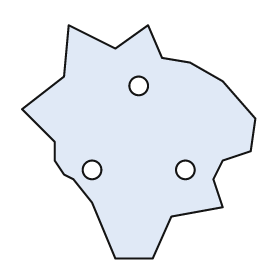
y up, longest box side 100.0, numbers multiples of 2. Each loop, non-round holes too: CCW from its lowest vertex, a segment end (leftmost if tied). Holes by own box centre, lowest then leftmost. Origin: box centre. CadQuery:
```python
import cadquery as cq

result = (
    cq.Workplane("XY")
    .moveTo(-10.0, -50.0)
    .lineTo(6.0, -50.0)
    .lineTo(14.0, -32.0)
    .lineTo(36.0, -28.0)
    .lineTo(32.0, -16.0)
    .lineTo(36.0, -8.0)
    .lineTo(48.0, -4.0)
    .lineTo(50.0, 10.0)
    .lineTo(36.0, 26.0)
    .lineTo(22.0, 34.0)
    .lineTo(10.0, 36.0)
    .lineTo(4.0, 50.0)
    .lineTo(-10.0, 40.0)
    .lineTo(-30.0, 50.0)
    .lineTo(-32.0, 28.0)
    .lineTo(-50.0, 14.0)
    .lineTo(-36.0, 0.0)
    .lineTo(-36.0, -8.0)
    .lineTo(-32.0, -14.0)
    .lineTo(-28.0, -16.0)
    .lineTo(-20.0, -26.0)
    .close()
    .moveTo(-20.0, -12.0)
    .circle(4.0)
    .moveTo(20.0, -12.0)
    .circle(4.0)
    .moveTo(0.0, 24.0)
    .circle(4.0)
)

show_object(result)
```